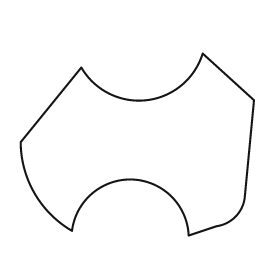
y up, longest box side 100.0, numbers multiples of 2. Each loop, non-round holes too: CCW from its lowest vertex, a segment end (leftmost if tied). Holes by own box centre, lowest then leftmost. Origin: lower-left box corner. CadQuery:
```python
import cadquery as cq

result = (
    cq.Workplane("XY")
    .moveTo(72.0, 0.0)
    .lineTo(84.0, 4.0)
    .threePointArc((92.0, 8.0), (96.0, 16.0))
    .lineTo(100.0, 58.0)
    .lineTo(78.0, 78.0)
    .threePointArc((54.0, 58.0), (26.0, 72.0))
    .lineTo(0.0, 40.0)
    .threePointArc((6.0, 18.0), (22.0, 2.0))
    .threePointArc((48.0, 24.0), (72.0, 0.0))
    .close()
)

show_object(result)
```